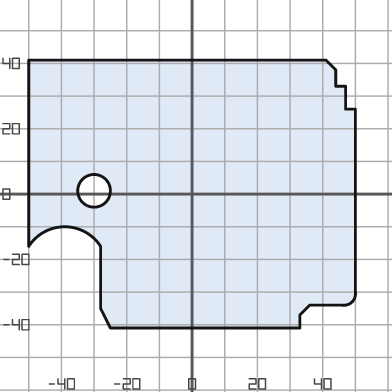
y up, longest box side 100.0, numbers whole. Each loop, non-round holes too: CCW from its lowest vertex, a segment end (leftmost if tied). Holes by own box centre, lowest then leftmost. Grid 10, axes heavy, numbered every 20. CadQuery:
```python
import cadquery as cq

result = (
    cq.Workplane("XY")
    .moveTo(-25.0, -41.0)
    .lineTo(33.0, -41.0)
    .lineTo(33.0, -37.0)
    .lineTo(36.0, -34.0)
    .lineTo(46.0, -34.0)
    .threePointArc((49.0, -33.0), (50.0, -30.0))
    .lineTo(50.0, 26.0)
    .lineTo(47.0, 26.0)
    .lineTo(47.0, 33.0)
    .lineTo(44.0, 33.0)
    .lineTo(44.0, 38.0)
    .lineTo(41.0, 41.0)
    .lineTo(-50.0, 41.0)
    .lineTo(-50.0, -16.0)
    .threePointArc((-39.0, -10.0), (-28.0, -16.0))
    .lineTo(-28.0, -35.0)
    .close()
    .moveTo(-30.0, 1.0)
    .circle(5.0)
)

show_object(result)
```